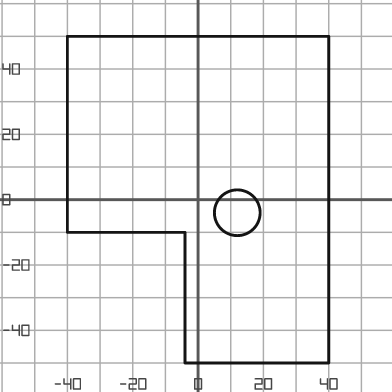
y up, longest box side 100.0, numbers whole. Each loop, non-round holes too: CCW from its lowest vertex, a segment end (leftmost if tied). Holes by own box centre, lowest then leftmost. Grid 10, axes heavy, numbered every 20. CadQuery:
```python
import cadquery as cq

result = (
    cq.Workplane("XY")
    .moveTo(-4.0, -50.0)
    .lineTo(40.0, -50.0)
    .lineTo(40.0, 50.0)
    .lineTo(-40.0, 50.0)
    .lineTo(-40.0, -10.0)
    .lineTo(-4.0, -10.0)
    .close()
    .moveTo(12.0, -4.0)
    .circle(7.0)
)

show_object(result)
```